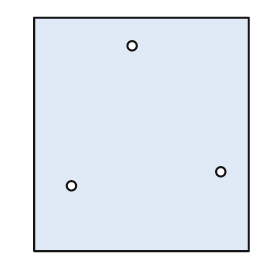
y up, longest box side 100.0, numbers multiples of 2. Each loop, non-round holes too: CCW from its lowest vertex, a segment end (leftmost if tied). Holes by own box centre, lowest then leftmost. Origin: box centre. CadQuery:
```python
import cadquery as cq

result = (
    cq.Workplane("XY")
    .moveTo(-46.0, -50.0)
    .lineTo(46.0, -50.0)
    .lineTo(46.0, 50.0)
    .lineTo(-46.0, 50.0)
    .close()
    .moveTo(-30.0, -22.0)
    .circle(2.0)
    .moveTo(34.0, -16.0)
    .circle(2.0)
    .moveTo(-4.0, 38.0)
    .circle(2.0)
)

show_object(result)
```